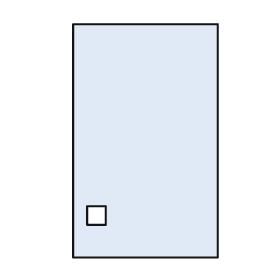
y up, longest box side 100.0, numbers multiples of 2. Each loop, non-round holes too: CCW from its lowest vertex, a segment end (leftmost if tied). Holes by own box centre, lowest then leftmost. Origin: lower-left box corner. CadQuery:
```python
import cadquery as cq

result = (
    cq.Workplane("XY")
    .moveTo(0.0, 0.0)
    .lineTo(62.0, 0.0)
    .lineTo(62.0, 100.0)
    .lineTo(0.0, 100.0)
    .close()
    .moveTo(6.0, 14.0)
    .lineTo(14.0, 14.0)
    .lineTo(14.0, 22.0)
    .lineTo(6.0, 22.0)
    .close()
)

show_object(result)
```